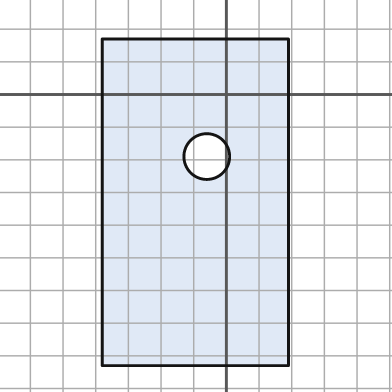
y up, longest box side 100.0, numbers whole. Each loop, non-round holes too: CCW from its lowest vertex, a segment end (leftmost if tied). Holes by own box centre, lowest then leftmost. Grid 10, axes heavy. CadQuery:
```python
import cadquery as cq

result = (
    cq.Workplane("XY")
    .moveTo(-38.0, -83.0)
    .lineTo(19.0, -83.0)
    .lineTo(19.0, 17.0)
    .lineTo(-38.0, 17.0)
    .close()
    .moveTo(-6.0, -19.0)
    .circle(7.0)
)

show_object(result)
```